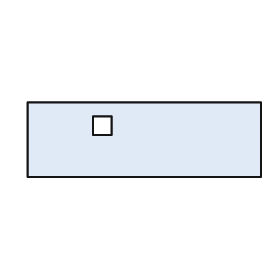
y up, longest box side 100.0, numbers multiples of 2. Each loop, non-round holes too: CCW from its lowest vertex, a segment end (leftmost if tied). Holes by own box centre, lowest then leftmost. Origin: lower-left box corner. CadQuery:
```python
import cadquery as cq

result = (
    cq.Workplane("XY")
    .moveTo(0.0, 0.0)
    .lineTo(100.0, 0.0)
    .lineTo(100.0, 32.0)
    .lineTo(0.0, 32.0)
    .close()
    .moveTo(28.0, 18.0)
    .lineTo(36.0, 18.0)
    .lineTo(36.0, 26.0)
    .lineTo(28.0, 26.0)
    .close()
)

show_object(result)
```